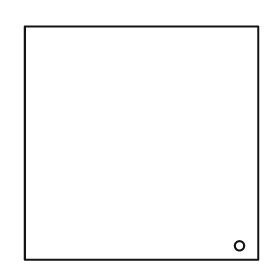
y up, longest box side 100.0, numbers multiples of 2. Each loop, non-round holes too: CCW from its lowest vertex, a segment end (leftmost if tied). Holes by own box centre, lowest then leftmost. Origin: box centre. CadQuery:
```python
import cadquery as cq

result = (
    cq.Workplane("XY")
    .moveTo(-50.0, -50.0)
    .lineTo(50.0, -50.0)
    .lineTo(50.0, 50.0)
    .lineTo(-50.0, 50.0)
    .close()
    .moveTo(42.0, -44.0)
    .circle(2.0)
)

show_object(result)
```